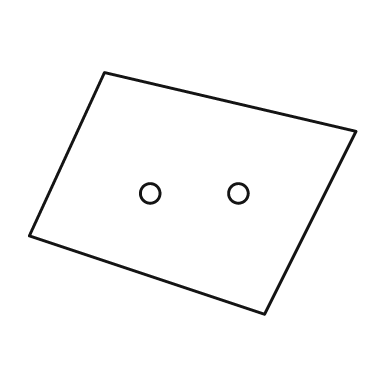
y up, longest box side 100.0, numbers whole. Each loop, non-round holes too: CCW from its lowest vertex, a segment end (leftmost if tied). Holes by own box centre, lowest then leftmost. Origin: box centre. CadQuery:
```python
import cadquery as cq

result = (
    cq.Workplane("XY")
    .moveTo(22.0, -37.0)
    .lineTo(50.0, 19.0)
    .lineTo(-27.0, 37.0)
    .lineTo(-50.0, -13.0)
    .close()
    .moveTo(-13.0, 0.0)
    .circle(3.0)
    .moveTo(14.0, 0.0)
    .circle(3.0)
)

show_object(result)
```